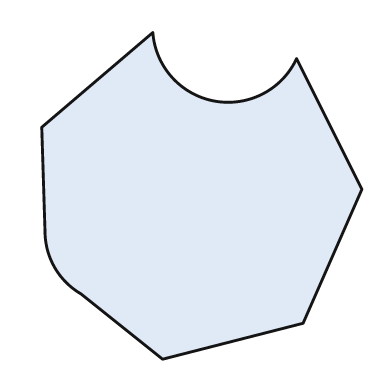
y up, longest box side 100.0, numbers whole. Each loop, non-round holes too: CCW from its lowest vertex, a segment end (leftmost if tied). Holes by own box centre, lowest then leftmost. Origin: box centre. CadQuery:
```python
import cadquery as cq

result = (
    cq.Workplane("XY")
    .moveTo(-12.0, -50.0)
    .lineTo(31.0, -39.0)
    .lineTo(49.0, 2.0)
    .lineTo(29.0, 42.0)
    .threePointArc((4.0, 29.0), (-15.0, 50.0))
    .lineTo(-49.0, 21.0)
    .lineTo(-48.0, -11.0)
    .threePointArc((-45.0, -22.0), (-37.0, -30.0))
    .close()
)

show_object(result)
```